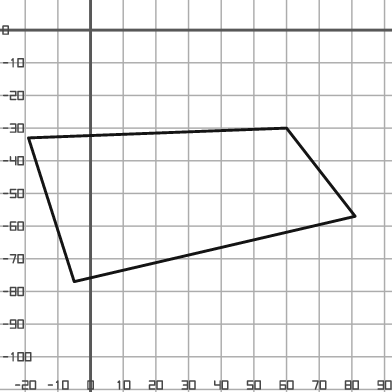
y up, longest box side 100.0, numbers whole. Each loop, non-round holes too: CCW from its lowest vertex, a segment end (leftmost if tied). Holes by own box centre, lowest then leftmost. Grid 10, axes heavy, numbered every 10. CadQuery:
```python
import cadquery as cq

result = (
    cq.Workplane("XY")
    .moveTo(-5.0, -77.0)
    .lineTo(81.0, -57.0)
    .lineTo(60.0, -30.0)
    .lineTo(-19.0, -33.0)
    .close()
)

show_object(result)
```